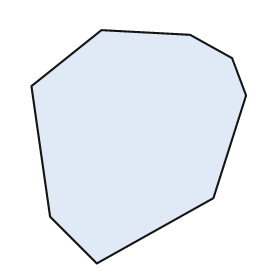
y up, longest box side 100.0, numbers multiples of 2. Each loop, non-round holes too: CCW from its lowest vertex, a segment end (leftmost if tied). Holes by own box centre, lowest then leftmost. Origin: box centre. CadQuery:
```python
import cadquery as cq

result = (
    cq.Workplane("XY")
    .moveTo(-18.0, -50.0)
    .lineTo(32.0, -22.0)
    .lineTo(46.0, 22.0)
    .lineTo(40.0, 38.0)
    .lineTo(22.0, 48.0)
    .lineTo(-16.0, 50.0)
    .lineTo(-46.0, 26.0)
    .lineTo(-38.0, -30.0)
    .close()
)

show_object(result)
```